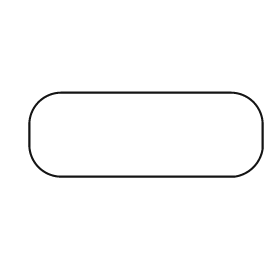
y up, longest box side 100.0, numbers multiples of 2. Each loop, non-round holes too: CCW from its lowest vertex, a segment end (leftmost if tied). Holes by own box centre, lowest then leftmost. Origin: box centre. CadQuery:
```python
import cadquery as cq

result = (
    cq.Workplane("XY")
    .moveTo(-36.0, -18.0)
    .lineTo(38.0, -18.0)
    .threePointArc((46.0, -14.0), (50.0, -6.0))
    .lineTo(50.0, 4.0)
    .threePointArc((46.0, 14.0), (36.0, 18.0))
    .lineTo(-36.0, 18.0)
    .threePointArc((-46.0, 14.0), (-50.0, 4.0))
    .lineTo(-50.0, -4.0)
    .threePointArc((-46.0, -14.0), (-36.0, -18.0))
    .close()
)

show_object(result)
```